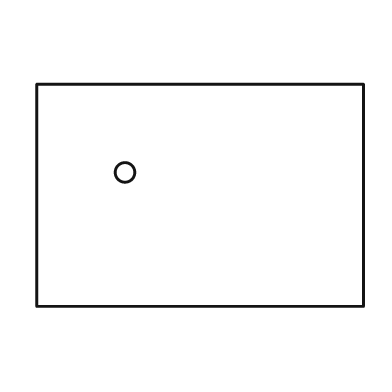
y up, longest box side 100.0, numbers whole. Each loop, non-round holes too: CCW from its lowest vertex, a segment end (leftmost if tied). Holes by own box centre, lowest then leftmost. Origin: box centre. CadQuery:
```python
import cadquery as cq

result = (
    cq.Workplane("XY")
    .moveTo(-50.0, -34.0)
    .lineTo(50.0, -34.0)
    .lineTo(50.0, 34.0)
    .lineTo(-50.0, 34.0)
    .close()
    .moveTo(-23.0, 7.0)
    .circle(3.0)
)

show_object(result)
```